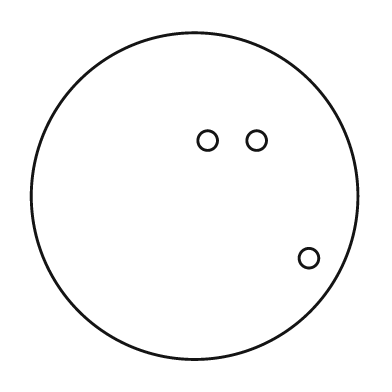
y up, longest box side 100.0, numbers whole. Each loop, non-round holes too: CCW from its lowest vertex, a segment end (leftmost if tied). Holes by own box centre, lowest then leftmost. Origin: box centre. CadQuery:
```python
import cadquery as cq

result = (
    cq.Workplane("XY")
    .moveTo(0.0, 0.0)
    .circle(50.0)
    .moveTo(35.0, -19.0)
    .circle(3.0)
    .moveTo(4.0, 17.0)
    .circle(3.0)
    .moveTo(19.0, 17.0)
    .circle(3.0)
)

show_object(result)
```